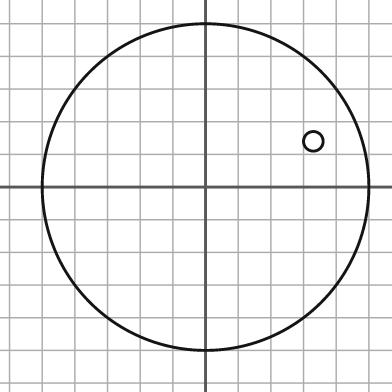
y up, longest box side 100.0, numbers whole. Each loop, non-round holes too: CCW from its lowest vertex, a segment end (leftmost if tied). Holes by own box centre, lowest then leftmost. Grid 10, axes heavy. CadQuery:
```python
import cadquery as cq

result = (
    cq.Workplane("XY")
    .moveTo(0.0, 0.0)
    .circle(50.0)
    .moveTo(33.0, 14.0)
    .circle(3.0)
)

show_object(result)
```